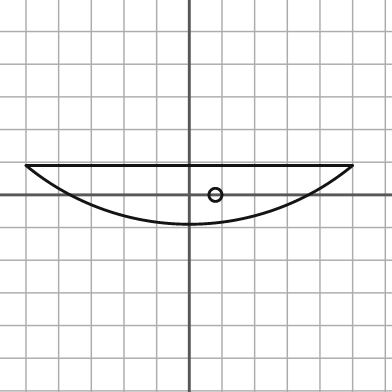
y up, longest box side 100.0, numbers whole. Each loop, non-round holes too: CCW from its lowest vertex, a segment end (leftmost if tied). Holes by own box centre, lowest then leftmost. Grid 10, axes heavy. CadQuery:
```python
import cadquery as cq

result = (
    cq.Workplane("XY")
    .moveTo(-50.0, 9.0)
    .threePointArc((0.0, -9.0), (50.0, 9.0))
    .close()
    .moveTo(8.0, 0.0)
    .circle(2.0)
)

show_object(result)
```